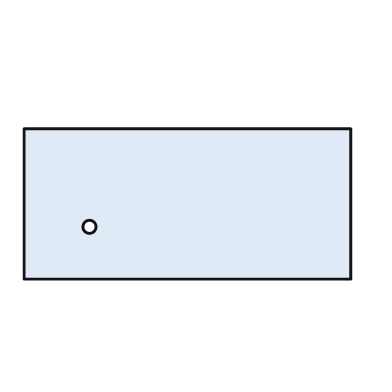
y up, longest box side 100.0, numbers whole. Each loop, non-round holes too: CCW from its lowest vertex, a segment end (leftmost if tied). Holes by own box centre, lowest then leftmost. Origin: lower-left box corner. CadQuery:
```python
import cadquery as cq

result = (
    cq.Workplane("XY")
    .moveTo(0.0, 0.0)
    .lineTo(100.0, 0.0)
    .lineTo(100.0, 46.0)
    .lineTo(0.0, 46.0)
    .close()
    .moveTo(20.0, 16.0)
    .circle(2.0)
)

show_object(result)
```